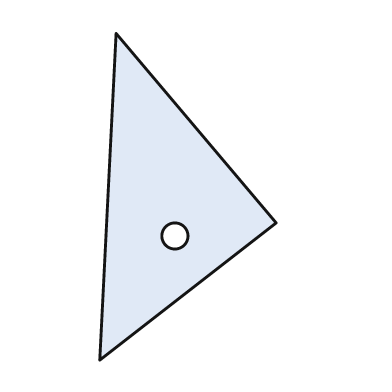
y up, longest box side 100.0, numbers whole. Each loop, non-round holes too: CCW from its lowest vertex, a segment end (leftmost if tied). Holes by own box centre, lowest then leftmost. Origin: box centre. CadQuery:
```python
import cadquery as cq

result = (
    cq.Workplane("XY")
    .moveTo(-27.0, -50.0)
    .lineTo(27.0, -8.0)
    .lineTo(-22.0, 50.0)
    .close()
    .moveTo(-4.0, -12.0)
    .circle(4.0)
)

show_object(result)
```